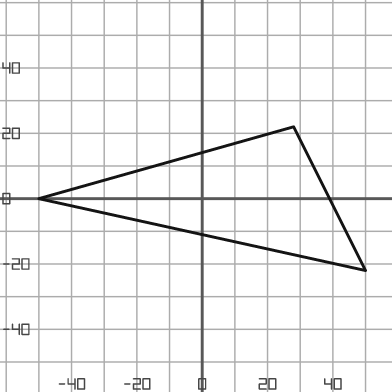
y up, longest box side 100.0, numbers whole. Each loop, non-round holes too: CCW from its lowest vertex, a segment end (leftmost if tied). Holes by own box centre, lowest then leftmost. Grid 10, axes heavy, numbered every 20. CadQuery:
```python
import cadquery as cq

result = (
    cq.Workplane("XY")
    .moveTo(50.0, -22.0)
    .lineTo(28.0, 22.0)
    .lineTo(-50.0, 0.0)
    .close()
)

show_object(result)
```